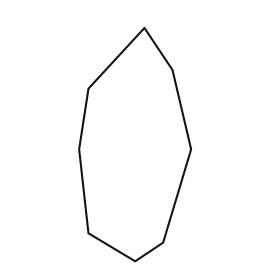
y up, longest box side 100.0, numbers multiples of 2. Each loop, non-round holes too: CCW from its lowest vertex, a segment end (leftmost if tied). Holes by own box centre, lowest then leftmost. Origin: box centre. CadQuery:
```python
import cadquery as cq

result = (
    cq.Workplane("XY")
    .moveTo(0.0, -50.0)
    .lineTo(12.0, -42.0)
    .lineTo(24.0, -2.0)
    .lineTo(16.0, 32.0)
    .lineTo(4.0, 50.0)
    .lineTo(-20.0, 24.0)
    .lineTo(-24.0, -2.0)
    .lineTo(-20.0, -38.0)
    .close()
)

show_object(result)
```